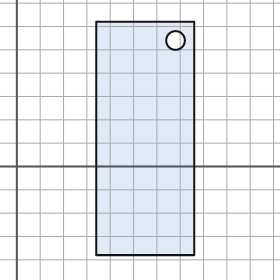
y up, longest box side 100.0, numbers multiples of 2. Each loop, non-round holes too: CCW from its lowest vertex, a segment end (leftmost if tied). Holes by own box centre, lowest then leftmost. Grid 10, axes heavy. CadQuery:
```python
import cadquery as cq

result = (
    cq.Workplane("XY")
    .moveTo(34.0, -38.0)
    .lineTo(76.0, -38.0)
    .lineTo(76.0, 62.0)
    .lineTo(34.0, 62.0)
    .close()
    .moveTo(68.0, 54.0)
    .circle(4.0)
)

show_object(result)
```